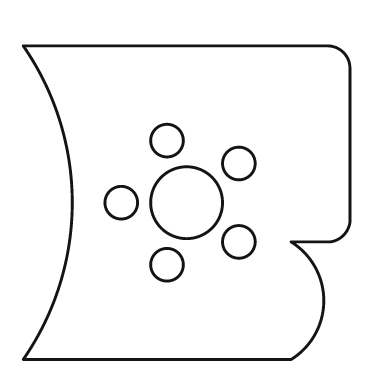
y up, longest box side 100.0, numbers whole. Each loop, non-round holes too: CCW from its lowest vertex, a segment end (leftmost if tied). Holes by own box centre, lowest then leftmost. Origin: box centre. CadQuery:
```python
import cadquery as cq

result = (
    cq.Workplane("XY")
    .moveTo(-50.0, -48.0)
    .lineTo(32.0, -48.0)
    .threePointArc((42.0, -30.0), (32.0, -12.0))
    .lineTo(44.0, -12.0)
    .threePointArc((48.0, -10.0), (50.0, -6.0))
    .lineTo(50.0, 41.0)
    .threePointArc((48.0, 46.0), (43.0, 48.0))
    .lineTo(-50.0, 48.0)
    .threePointArc((-35.0, 0.0), (-50.0, -48.0))
    .close()
    .moveTo(-6.0, -19.0)
    .circle(5.0)
    .moveTo(16.0, -12.0)
    .circle(5.0)
    .moveTo(-20.0, 0.0)
    .circle(5.0)
    .moveTo(0.0, 0.0)
    .circle(11.0)
    .moveTo(16.0, 12.0)
    .circle(5.0)
    .moveTo(-6.0, 19.0)
    .circle(5.0)
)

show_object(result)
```